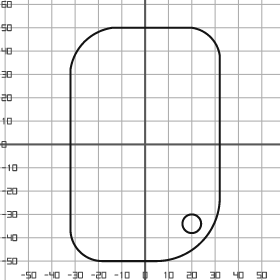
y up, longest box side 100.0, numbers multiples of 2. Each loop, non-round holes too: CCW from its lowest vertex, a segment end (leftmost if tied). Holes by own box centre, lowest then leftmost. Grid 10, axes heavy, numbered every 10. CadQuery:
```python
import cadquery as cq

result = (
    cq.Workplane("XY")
    .moveTo(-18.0, -50.0)
    .lineTo(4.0, -50.0)
    .threePointArc((24.0, -42.0), (32.0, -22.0))
    .lineTo(32.0, 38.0)
    .threePointArc((28.0, 46.0), (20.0, 50.0))
    .lineTo(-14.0, 50.0)
    .threePointArc((-26.0, 44.0), (-32.0, 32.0))
    .lineTo(-32.0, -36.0)
    .threePointArc((-28.0, -46.0), (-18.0, -50.0))
    .close()
    .moveTo(20.0, -34.0)
    .circle(4.0)
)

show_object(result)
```